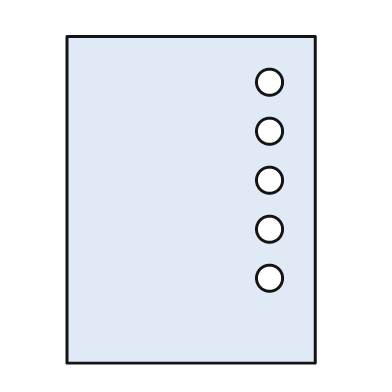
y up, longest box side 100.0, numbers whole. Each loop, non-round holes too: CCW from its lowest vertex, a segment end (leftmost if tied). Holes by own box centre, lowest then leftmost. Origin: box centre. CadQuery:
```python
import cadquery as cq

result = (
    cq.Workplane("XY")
    .moveTo(-38.0, -50.0)
    .lineTo(38.0, -50.0)
    .lineTo(38.0, 50.0)
    .lineTo(-38.0, 50.0)
    .close()
    .moveTo(24.0, -24.0)
    .circle(4.0)
    .moveTo(24.0, -9.0)
    .circle(4.0)
    .moveTo(24.0, 6.0)
    .circle(4.0)
    .moveTo(24.0, 21.0)
    .circle(4.0)
    .moveTo(24.0, 36.0)
    .circle(4.0)
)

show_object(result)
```